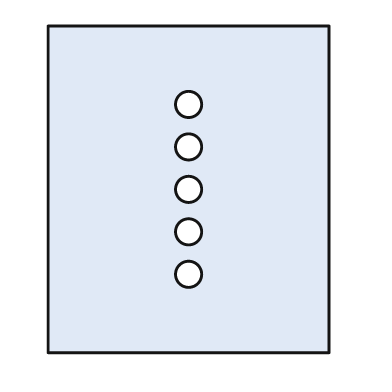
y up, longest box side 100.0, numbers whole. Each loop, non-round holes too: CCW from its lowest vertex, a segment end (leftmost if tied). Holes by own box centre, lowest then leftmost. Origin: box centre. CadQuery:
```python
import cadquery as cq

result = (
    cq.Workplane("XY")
    .moveTo(-43.0, -50.0)
    .lineTo(43.0, -50.0)
    .lineTo(43.0, 50.0)
    .lineTo(-43.0, 50.0)
    .close()
    .moveTo(0.0, -26.0)
    .circle(4.0)
    .moveTo(0.0, -13.0)
    .circle(4.0)
    .moveTo(0.0, 0.0)
    .circle(4.0)
    .moveTo(0.0, 13.0)
    .circle(4.0)
    .moveTo(0.0, 26.0)
    .circle(4.0)
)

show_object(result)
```